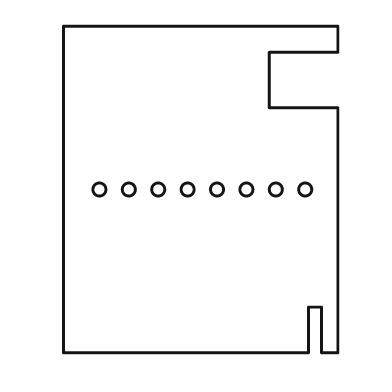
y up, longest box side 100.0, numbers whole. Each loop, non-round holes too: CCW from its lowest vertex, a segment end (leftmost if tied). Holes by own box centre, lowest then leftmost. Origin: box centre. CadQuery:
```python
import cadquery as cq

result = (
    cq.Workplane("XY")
    .moveTo(-42.0, -50.0)
    .lineTo(33.0, -50.0)
    .lineTo(33.0, -36.0)
    .lineTo(37.0, -36.0)
    .lineTo(37.0, -50.0)
    .lineTo(42.0, -50.0)
    .lineTo(42.0, 25.0)
    .lineTo(21.0, 25.0)
    .lineTo(21.0, 42.0)
    .lineTo(42.0, 42.0)
    .lineTo(42.0, 50.0)
    .lineTo(-42.0, 50.0)
    .close()
    .moveTo(-31.0, 0.0)
    .circle(2.0)
    .moveTo(-22.0, 0.0)
    .circle(2.0)
    .moveTo(-13.0, 0.0)
    .circle(2.0)
    .moveTo(-4.0, 0.0)
    .circle(2.0)
    .moveTo(5.0, 0.0)
    .circle(2.0)
    .moveTo(14.0, 0.0)
    .circle(2.0)
    .moveTo(23.0, 0.0)
    .circle(2.0)
    .moveTo(32.0, 0.0)
    .circle(2.0)
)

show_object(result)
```